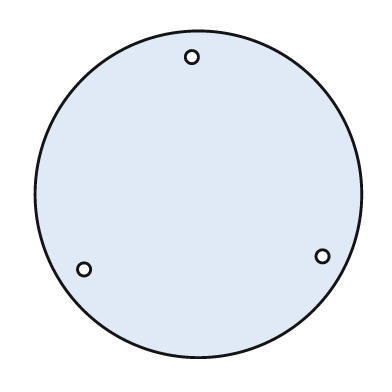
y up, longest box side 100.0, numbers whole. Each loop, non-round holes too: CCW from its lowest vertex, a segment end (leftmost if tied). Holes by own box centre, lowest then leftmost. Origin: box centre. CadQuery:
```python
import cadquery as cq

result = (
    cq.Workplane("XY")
    .moveTo(0.0, 0.0)
    .circle(50.0)
    .moveTo(-35.0, -23.0)
    .circle(2.0)
    .moveTo(38.0, -19.0)
    .circle(2.0)
    .moveTo(-2.0, 42.0)
    .circle(2.0)
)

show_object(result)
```